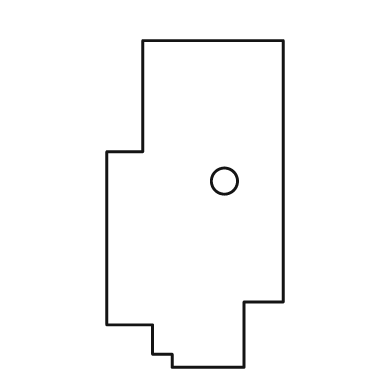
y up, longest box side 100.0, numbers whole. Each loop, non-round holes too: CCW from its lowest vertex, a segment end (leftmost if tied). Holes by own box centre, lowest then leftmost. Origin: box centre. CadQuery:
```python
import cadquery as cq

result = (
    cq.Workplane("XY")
    .moveTo(-7.0, -50.0)
    .lineTo(15.0, -50.0)
    .lineTo(15.0, -30.0)
    .lineTo(27.0, -30.0)
    .lineTo(27.0, 50.0)
    .lineTo(-16.0, 50.0)
    .lineTo(-16.0, 16.0)
    .lineTo(-27.0, 16.0)
    .lineTo(-27.0, -37.0)
    .lineTo(-13.0, -37.0)
    .lineTo(-13.0, -46.0)
    .lineTo(-7.0, -46.0)
    .close()
    .moveTo(9.0, 7.0)
    .circle(4.0)
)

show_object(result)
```